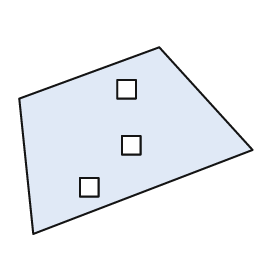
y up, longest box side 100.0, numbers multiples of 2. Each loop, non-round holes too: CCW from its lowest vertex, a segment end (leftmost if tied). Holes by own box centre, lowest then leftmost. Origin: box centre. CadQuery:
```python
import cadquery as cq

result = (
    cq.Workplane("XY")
    .moveTo(-44.0, -40.0)
    .lineTo(50.0, -4.0)
    .lineTo(10.0, 40.0)
    .lineTo(-50.0, 18.0)
    .close()
    .moveTo(-24.0, -24.0)
    .lineTo(-16.0, -24.0)
    .lineTo(-16.0, -16.0)
    .lineTo(-24.0, -16.0)
    .close()
    .moveTo(-6.0, -6.0)
    .lineTo(2.0, -6.0)
    .lineTo(2.0, 2.0)
    .lineTo(-6.0, 2.0)
    .close()
    .moveTo(-8.0, 18.0)
    .lineTo(0.0, 18.0)
    .lineTo(0.0, 26.0)
    .lineTo(-8.0, 26.0)
    .close()
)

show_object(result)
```